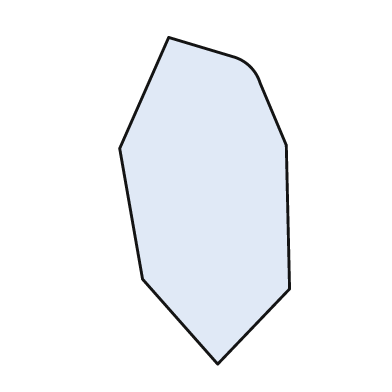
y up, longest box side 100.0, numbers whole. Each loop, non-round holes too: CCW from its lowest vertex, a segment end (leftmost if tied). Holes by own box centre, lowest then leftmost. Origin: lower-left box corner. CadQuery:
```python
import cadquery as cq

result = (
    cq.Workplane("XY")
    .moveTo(30.0, 0.0)
    .lineTo(52.0, 23.0)
    .lineTo(51.0, 67.0)
    .lineTo(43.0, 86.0)
    .threePointArc((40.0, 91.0), (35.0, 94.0))
    .lineTo(15.0, 100.0)
    .lineTo(0.0, 66.0)
    .lineTo(7.0, 26.0)
    .close()
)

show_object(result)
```